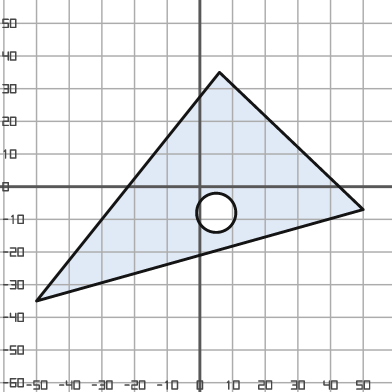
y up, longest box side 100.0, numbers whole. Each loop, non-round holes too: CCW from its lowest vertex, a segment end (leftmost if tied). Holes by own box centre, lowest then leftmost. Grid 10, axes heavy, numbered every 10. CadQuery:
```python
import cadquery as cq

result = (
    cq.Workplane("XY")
    .moveTo(-50.0, -35.0)
    .lineTo(50.0, -7.0)
    .lineTo(6.0, 35.0)
    .close()
    .moveTo(5.0, -8.0)
    .circle(6.0)
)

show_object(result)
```